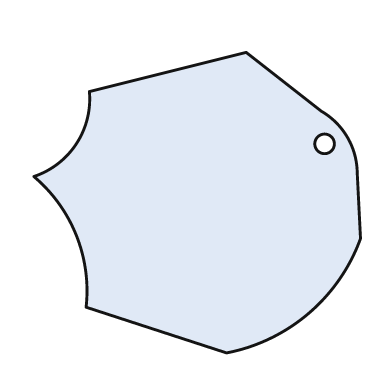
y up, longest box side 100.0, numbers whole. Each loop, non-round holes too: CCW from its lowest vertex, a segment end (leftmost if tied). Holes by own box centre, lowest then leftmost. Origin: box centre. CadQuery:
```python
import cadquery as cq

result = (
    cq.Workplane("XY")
    .moveTo(9.0, -46.0)
    .threePointArc((34.0, -34.0), (50.0, -11.0))
    .lineTo(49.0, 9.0)
    .threePointArc((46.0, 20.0), (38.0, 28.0))
    .lineTo(15.0, 46.0)
    .lineTo(-33.0, 34.0)
    .threePointArc((-37.0, 18.0), (-50.0, 8.0))
    .threePointArc((-37.0, -10.0), (-34.0, -32.0))
    .close()
    .moveTo(39.0, 18.0)
    .circle(3.0)
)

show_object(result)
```